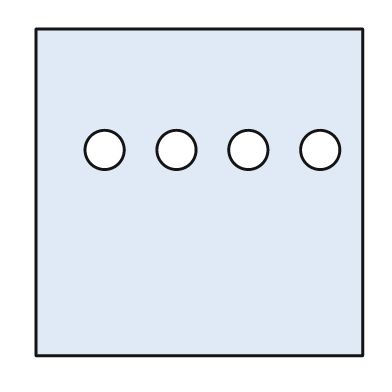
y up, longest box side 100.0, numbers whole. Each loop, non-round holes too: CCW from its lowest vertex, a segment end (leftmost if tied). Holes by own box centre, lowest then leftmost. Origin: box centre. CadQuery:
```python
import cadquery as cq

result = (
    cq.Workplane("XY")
    .moveTo(-50.0, -50.0)
    .lineTo(50.0, -50.0)
    .lineTo(50.0, 50.0)
    .lineTo(-50.0, 50.0)
    .close()
    .moveTo(-29.0, 13.0)
    .circle(6.0)
    .moveTo(-7.0, 13.0)
    .circle(6.0)
    .moveTo(15.0, 13.0)
    .circle(6.0)
    .moveTo(37.0, 13.0)
    .circle(6.0)
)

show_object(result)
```